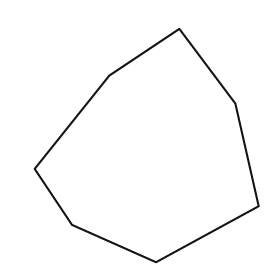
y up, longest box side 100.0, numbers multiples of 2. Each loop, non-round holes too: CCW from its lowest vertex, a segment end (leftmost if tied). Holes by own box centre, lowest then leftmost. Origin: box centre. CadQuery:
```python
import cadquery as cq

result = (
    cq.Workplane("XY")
    .moveTo(4.0, -50.0)
    .lineTo(48.0, -26.0)
    .lineTo(38.0, 18.0)
    .lineTo(14.0, 50.0)
    .lineTo(-16.0, 30.0)
    .lineTo(-48.0, -10.0)
    .lineTo(-32.0, -34.0)
    .close()
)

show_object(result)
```